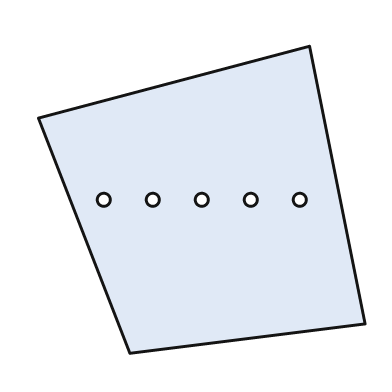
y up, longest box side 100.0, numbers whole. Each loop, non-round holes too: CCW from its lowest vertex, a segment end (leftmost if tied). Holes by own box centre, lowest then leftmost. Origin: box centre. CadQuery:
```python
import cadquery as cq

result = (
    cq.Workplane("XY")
    .moveTo(-22.0, -47.0)
    .lineTo(50.0, -38.0)
    .lineTo(33.0, 47.0)
    .lineTo(-50.0, 25.0)
    .close()
    .moveTo(-30.0, 0.0)
    .circle(2.0)
    .moveTo(-15.0, 0.0)
    .circle(2.0)
    .moveTo(0.0, 0.0)
    .circle(2.0)
    .moveTo(15.0, 0.0)
    .circle(2.0)
    .moveTo(30.0, 0.0)
    .circle(2.0)
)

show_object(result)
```